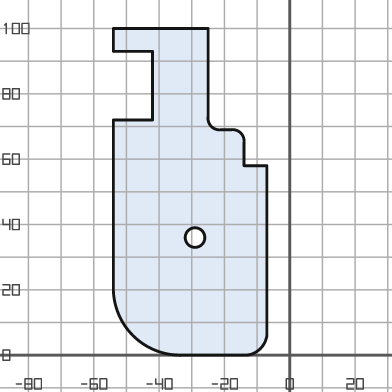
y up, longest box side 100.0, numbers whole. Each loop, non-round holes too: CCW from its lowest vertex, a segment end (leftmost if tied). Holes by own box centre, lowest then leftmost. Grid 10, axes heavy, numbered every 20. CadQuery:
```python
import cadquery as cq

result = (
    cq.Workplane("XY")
    .moveTo(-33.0, 0.0)
    .lineTo(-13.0, 0.0)
    .threePointArc((-9.0, 2.0), (-7.0, 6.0))
    .lineTo(-7.0, 58.0)
    .lineTo(-14.0, 58.0)
    .lineTo(-14.0, 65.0)
    .threePointArc((-15.0, 68.0), (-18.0, 69.0))
    .lineTo(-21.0, 69.0)
    .threePointArc((-24.0, 70.0), (-25.0, 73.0))
    .lineTo(-25.0, 100.0)
    .lineTo(-54.0, 100.0)
    .lineTo(-54.0, 93.0)
    .lineTo(-42.0, 93.0)
    .lineTo(-42.0, 72.0)
    .lineTo(-54.0, 72.0)
    .lineTo(-54.0, 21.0)
    .threePointArc((-48.0, 6.0), (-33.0, 0.0))
    .close()
    .moveTo(-29.0, 36.0)
    .circle(3.0)
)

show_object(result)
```